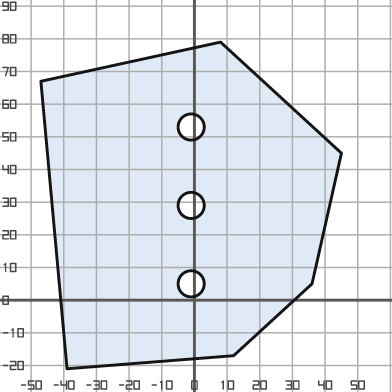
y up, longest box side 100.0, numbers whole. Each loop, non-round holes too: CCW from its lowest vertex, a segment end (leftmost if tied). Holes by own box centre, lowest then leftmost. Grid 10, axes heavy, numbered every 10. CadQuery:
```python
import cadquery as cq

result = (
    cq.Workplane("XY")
    .moveTo(-39.0, -21.0)
    .lineTo(12.0, -17.0)
    .lineTo(36.0, 5.0)
    .lineTo(45.0, 45.0)
    .lineTo(8.0, 79.0)
    .lineTo(-47.0, 67.0)
    .close()
    .moveTo(-1.0, 5.0)
    .circle(4.0)
    .moveTo(-1.0, 29.0)
    .circle(4.0)
    .moveTo(-1.0, 53.0)
    .circle(4.0)
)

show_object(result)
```